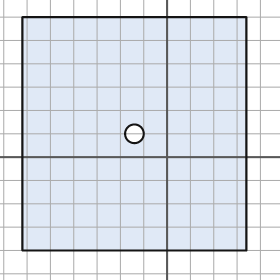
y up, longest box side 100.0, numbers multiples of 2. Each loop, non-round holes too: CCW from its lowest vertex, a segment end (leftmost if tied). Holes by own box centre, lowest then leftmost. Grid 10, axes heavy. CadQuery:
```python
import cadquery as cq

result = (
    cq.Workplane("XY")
    .moveTo(-62.0, -40.0)
    .lineTo(34.0, -40.0)
    .lineTo(34.0, 60.0)
    .lineTo(-62.0, 60.0)
    .close()
    .moveTo(-14.0, 10.0)
    .circle(4.0)
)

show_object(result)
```